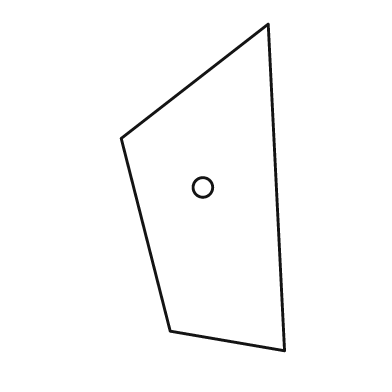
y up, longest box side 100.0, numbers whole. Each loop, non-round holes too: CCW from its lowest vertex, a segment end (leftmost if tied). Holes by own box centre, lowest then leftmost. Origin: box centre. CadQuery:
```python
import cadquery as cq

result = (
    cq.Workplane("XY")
    .moveTo(25.0, -50.0)
    .lineTo(20.0, 50.0)
    .lineTo(-25.0, 15.0)
    .lineTo(-10.0, -44.0)
    .close()
    .moveTo(0.0, 0.0)
    .circle(3.0)
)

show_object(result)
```